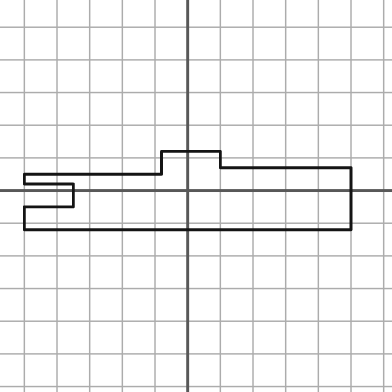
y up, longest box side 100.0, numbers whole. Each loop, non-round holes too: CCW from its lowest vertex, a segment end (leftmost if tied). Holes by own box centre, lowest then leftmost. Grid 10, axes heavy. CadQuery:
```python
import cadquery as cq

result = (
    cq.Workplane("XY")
    .moveTo(-50.0, -12.0)
    .lineTo(50.0, -12.0)
    .lineTo(50.0, 7.0)
    .lineTo(10.0, 7.0)
    .lineTo(10.0, 12.0)
    .lineTo(-8.0, 12.0)
    .lineTo(-8.0, 5.0)
    .lineTo(-50.0, 5.0)
    .lineTo(-50.0, 2.0)
    .lineTo(-35.0, 2.0)
    .lineTo(-35.0, -5.0)
    .lineTo(-50.0, -5.0)
    .close()
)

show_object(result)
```